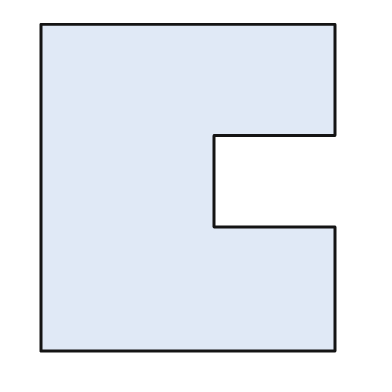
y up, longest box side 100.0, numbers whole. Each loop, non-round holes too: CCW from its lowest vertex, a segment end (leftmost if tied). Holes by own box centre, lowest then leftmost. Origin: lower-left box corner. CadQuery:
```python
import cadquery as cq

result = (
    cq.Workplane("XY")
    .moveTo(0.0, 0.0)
    .lineTo(90.0, 0.0)
    .lineTo(90.0, 38.0)
    .lineTo(53.0, 38.0)
    .lineTo(53.0, 66.0)
    .lineTo(90.0, 66.0)
    .lineTo(90.0, 100.0)
    .lineTo(0.0, 100.0)
    .close()
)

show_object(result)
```